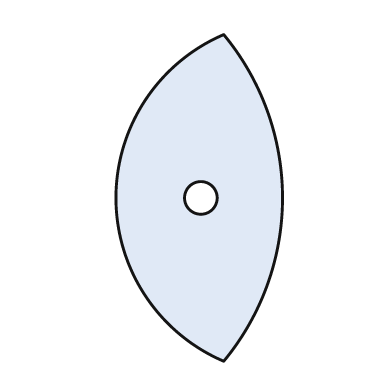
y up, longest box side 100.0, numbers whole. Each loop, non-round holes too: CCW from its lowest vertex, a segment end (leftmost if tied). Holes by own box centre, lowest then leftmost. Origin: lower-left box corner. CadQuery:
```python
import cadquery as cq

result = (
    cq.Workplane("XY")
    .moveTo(33.0, 0.0)
    .threePointArc((51.0, 50.0), (33.0, 100.0))
    .threePointArc((0.0, 50.0), (33.0, 0.0))
    .close()
    .moveTo(26.0, 50.0)
    .circle(5.0)
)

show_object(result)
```